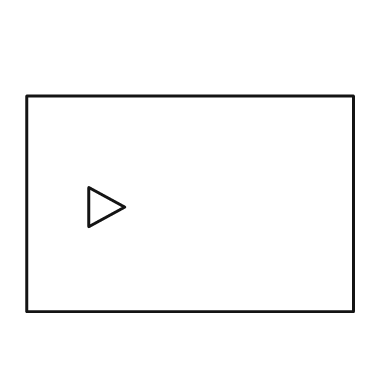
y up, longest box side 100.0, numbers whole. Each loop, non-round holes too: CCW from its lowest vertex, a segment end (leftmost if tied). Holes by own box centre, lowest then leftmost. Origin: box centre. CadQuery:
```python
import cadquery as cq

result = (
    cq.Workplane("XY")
    .moveTo(-50.0, -33.0)
    .lineTo(50.0, -33.0)
    .lineTo(50.0, 33.0)
    .lineTo(-50.0, 33.0)
    .close()
    .moveTo(-31.0, -7.0)
    .lineTo(-20.0, -1.0)
    .lineTo(-31.0, 5.0)
    .close()
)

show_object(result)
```